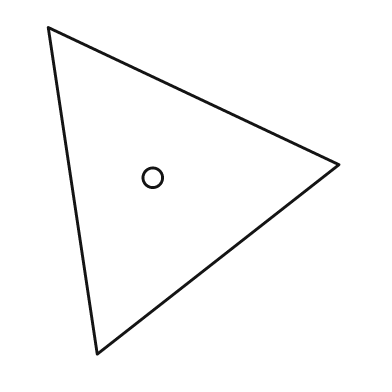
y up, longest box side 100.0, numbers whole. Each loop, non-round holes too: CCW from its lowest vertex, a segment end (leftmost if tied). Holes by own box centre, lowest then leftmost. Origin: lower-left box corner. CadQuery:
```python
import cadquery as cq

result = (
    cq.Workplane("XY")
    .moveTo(15.0, 0.0)
    .lineTo(89.0, 58.0)
    .lineTo(0.0, 100.0)
    .close()
    .moveTo(32.0, 54.0)
    .circle(3.0)
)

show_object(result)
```